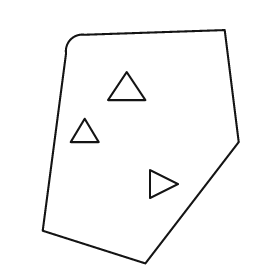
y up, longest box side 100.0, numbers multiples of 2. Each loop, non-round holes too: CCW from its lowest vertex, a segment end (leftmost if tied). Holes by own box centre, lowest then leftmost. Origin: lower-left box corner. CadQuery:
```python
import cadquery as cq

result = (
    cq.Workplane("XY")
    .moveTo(44.0, 0.0)
    .lineTo(84.0, 52.0)
    .lineTo(78.0, 100.0)
    .lineTo(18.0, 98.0)
    .threePointArc((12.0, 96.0), (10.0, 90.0))
    .lineTo(0.0, 14.0)
    .close()
    .moveTo(46.0, 28.0)
    .lineTo(58.0, 34.0)
    .lineTo(46.0, 40.0)
    .close()
    .moveTo(12.0, 52.0)
    .lineTo(24.0, 52.0)
    .lineTo(18.0, 62.0)
    .close()
    .moveTo(28.0, 70.0)
    .lineTo(44.0, 70.0)
    .lineTo(36.0, 82.0)
    .close()
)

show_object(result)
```